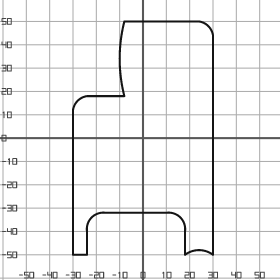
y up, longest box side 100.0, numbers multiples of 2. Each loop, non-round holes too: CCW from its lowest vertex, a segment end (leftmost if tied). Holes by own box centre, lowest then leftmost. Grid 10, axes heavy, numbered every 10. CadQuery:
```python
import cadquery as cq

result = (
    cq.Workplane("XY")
    .moveTo(-30.0, -50.0)
    .lineTo(-24.0, -50.0)
    .lineTo(-24.0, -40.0)
    .threePointArc((-22.0, -34.0), (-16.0, -32.0))
    .lineTo(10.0, -32.0)
    .threePointArc((16.0, -34.0), (18.0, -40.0))
    .lineTo(18.0, -50.0)
    .threePointArc((24.0, -48.0), (30.0, -50.0))
    .lineTo(30.0, 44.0)
    .threePointArc((28.0, 48.0), (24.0, 50.0))
    .lineTo(-8.0, 50.0)
    .threePointArc((-10.0, 34.0), (-8.0, 18.0))
    .lineTo(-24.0, 18.0)
    .threePointArc((-28.0, 16.0), (-30.0, 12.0))
    .close()
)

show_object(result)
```